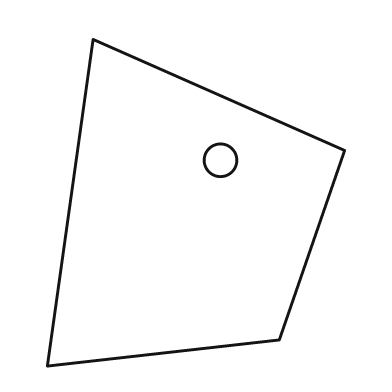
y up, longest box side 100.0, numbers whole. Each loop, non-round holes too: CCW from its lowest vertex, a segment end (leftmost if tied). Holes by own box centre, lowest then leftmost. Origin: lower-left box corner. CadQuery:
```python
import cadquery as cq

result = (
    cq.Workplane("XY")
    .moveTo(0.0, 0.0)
    .lineTo(71.0, 8.0)
    .lineTo(91.0, 66.0)
    .lineTo(14.0, 100.0)
    .close()
    .moveTo(53.0, 63.0)
    .circle(5.0)
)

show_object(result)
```